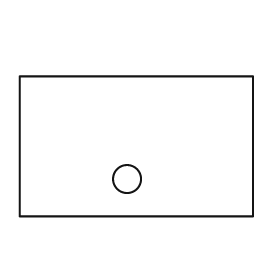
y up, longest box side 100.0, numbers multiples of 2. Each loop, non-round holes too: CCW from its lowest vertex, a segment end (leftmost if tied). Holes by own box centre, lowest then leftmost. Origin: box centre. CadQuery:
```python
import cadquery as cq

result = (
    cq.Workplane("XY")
    .moveTo(-50.0, -30.0)
    .lineTo(50.0, -30.0)
    .lineTo(50.0, 30.0)
    .lineTo(-50.0, 30.0)
    .close()
    .moveTo(-4.0, -14.0)
    .circle(6.0)
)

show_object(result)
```